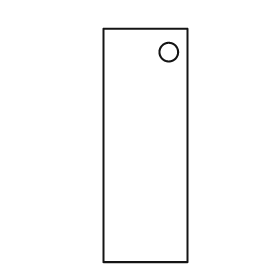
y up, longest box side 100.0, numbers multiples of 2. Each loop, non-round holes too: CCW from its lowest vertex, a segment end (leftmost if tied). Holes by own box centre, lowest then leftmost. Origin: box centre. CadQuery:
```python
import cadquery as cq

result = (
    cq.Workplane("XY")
    .moveTo(-18.0, -50.0)
    .lineTo(18.0, -50.0)
    .lineTo(18.0, 50.0)
    .lineTo(-18.0, 50.0)
    .close()
    .moveTo(10.0, 40.0)
    .circle(4.0)
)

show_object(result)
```